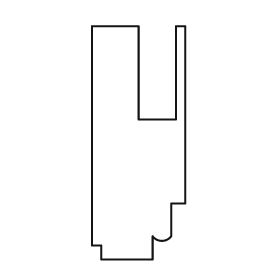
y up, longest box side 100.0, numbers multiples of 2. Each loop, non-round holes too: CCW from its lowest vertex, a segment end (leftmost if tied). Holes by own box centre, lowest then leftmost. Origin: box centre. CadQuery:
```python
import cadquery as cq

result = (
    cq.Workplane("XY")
    .moveTo(-16.0, -50.0)
    .lineTo(6.0, -50.0)
    .lineTo(6.0, -40.0)
    .threePointArc((10.0, -42.0), (14.0, -40.0))
    .lineTo(14.0, -26.0)
    .lineTo(20.0, -26.0)
    .lineTo(20.0, 50.0)
    .lineTo(16.0, 50.0)
    .lineTo(16.0, 10.0)
    .lineTo(0.0, 10.0)
    .lineTo(0.0, 50.0)
    .lineTo(-20.0, 50.0)
    .lineTo(-20.0, -44.0)
    .lineTo(-16.0, -44.0)
    .close()
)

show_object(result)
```